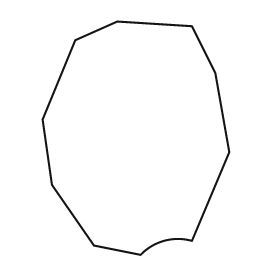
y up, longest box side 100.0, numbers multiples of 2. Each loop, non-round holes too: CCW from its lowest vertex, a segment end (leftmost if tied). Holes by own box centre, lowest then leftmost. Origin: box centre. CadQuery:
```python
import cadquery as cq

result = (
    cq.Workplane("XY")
    .moveTo(2.0, -50.0)
    .threePointArc((12.0, -44.0), (24.0, -44.0))
    .lineTo(40.0, -6.0)
    .lineTo(34.0, 28.0)
    .lineTo(24.0, 48.0)
    .lineTo(-8.0, 50.0)
    .lineTo(-26.0, 42.0)
    .lineTo(-40.0, 8.0)
    .lineTo(-36.0, -20.0)
    .lineTo(-18.0, -46.0)
    .close()
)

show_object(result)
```